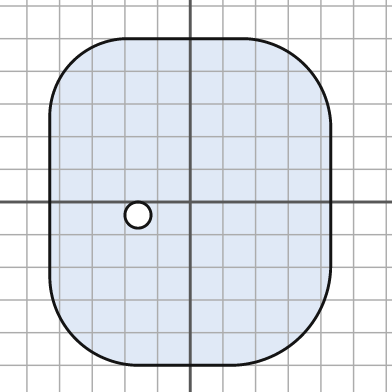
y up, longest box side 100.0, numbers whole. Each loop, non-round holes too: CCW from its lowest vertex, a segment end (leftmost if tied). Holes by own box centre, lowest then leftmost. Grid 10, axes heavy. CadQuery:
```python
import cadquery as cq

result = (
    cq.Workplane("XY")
    .moveTo(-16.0, -50.0)
    .lineTo(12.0, -50.0)
    .threePointArc((34.0, -41.0), (43.0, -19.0))
    .lineTo(43.0, 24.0)
    .threePointArc((35.0, 42.0), (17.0, 50.0))
    .lineTo(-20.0, 50.0)
    .threePointArc((-36.0, 43.0), (-43.0, 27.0))
    .lineTo(-43.0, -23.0)
    .threePointArc((-35.0, -42.0), (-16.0, -50.0))
    .close()
    .moveTo(-16.0, -4.0)
    .circle(4.0)
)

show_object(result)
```